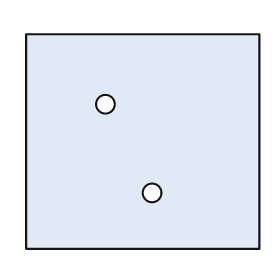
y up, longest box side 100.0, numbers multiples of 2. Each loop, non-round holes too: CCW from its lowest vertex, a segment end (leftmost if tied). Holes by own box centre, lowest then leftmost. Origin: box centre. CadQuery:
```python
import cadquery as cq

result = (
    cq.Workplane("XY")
    .moveTo(-50.0, -46.0)
    .lineTo(50.0, -46.0)
    .lineTo(50.0, 46.0)
    .lineTo(-50.0, 46.0)
    .close()
    .moveTo(4.0, -22.0)
    .circle(4.0)
    .moveTo(-16.0, 16.0)
    .circle(4.0)
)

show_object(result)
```